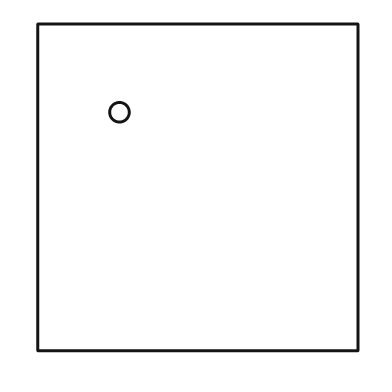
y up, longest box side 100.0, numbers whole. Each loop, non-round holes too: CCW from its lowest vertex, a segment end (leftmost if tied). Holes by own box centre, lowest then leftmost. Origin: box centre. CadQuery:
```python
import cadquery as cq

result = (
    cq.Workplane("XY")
    .moveTo(-49.0, -50.0)
    .lineTo(49.0, -50.0)
    .lineTo(49.0, 50.0)
    .lineTo(-49.0, 50.0)
    .close()
    .moveTo(-24.0, 23.0)
    .circle(3.0)
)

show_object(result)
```